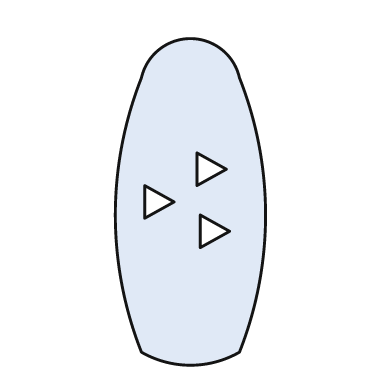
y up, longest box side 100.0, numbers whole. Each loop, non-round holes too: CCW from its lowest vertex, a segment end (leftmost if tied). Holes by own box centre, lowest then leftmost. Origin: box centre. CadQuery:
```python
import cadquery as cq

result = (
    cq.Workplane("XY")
    .moveTo(-15.0, -46.0)
    .threePointArc((0.0, -50.0), (15.0, -46.0))
    .threePointArc((23.0, -4.0), (15.0, 38.0))
    .threePointArc((0.0, 50.0), (-15.0, 38.0))
    .threePointArc((-23.0, -4.0), (-15.0, -46.0))
    .close()
    .moveTo(3.0, -14.0)
    .lineTo(12.0, -9.0)
    .lineTo(3.0, -4.0)
    .close()
    .moveTo(-14.0, -5.0)
    .lineTo(-5.0, 0.0)
    .lineTo(-14.0, 5.0)
    .close()
    .moveTo(2.0, 5.0)
    .lineTo(11.0, 10.0)
    .lineTo(2.0, 15.0)
    .close()
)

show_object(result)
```